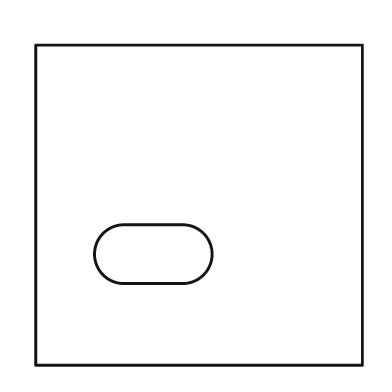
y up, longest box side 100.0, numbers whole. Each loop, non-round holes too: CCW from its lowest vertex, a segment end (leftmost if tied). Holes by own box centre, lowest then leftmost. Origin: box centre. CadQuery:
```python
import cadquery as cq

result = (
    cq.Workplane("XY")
    .moveTo(-50.0, -49.0)
    .lineTo(50.0, -49.0)
    .lineTo(50.0, 49.0)
    .lineTo(-50.0, 49.0)
    .close()
    .moveTo(-23.0, -24.0)
    .lineTo(-5.0, -24.0)
    .threePointArc((4.0, -15.0), (-5.0, -6.0))
    .lineTo(-23.0, -6.0)
    .threePointArc((-32.0, -15.0), (-23.0, -24.0))
    .close()
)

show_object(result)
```